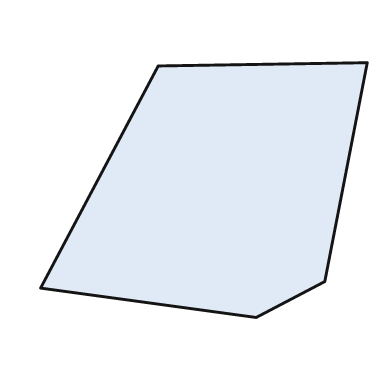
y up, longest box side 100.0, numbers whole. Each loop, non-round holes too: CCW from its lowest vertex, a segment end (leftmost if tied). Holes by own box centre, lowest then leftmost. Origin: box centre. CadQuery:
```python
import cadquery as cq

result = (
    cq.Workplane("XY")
    .moveTo(16.0, -39.0)
    .lineTo(37.0, -28.0)
    .lineTo(50.0, 39.0)
    .lineTo(-14.0, 38.0)
    .lineTo(-50.0, -30.0)
    .close()
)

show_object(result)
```